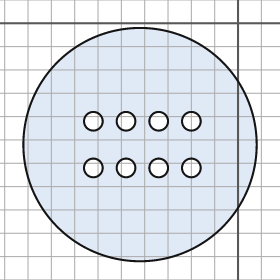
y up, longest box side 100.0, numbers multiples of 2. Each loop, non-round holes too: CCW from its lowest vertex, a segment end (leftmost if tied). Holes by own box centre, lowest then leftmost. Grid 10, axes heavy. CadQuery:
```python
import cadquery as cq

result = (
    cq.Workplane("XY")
    .moveTo(-42.0, -52.0)
    .circle(50.0)
    .moveTo(-62.0, -62.0)
    .circle(4.0)
    .moveTo(-48.0, -62.0)
    .circle(4.0)
    .moveTo(-34.0, -62.0)
    .circle(4.0)
    .moveTo(-20.0, -62.0)
    .circle(4.0)
    .moveTo(-62.0, -42.0)
    .circle(4.0)
    .moveTo(-48.0, -42.0)
    .circle(4.0)
    .moveTo(-34.0, -42.0)
    .circle(4.0)
    .moveTo(-20.0, -42.0)
    .circle(4.0)
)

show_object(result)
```